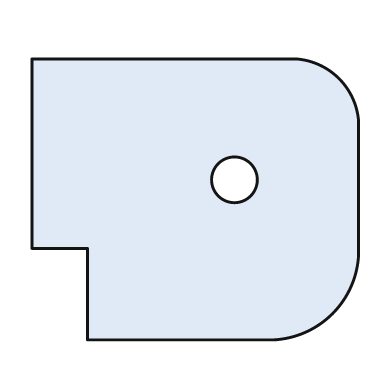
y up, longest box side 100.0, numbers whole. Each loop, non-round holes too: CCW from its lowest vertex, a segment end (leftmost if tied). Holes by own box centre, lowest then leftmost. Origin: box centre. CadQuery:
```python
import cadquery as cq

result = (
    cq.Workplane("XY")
    .moveTo(-33.0, -43.0)
    .lineTo(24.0, -43.0)
    .threePointArc((42.0, -35.0), (50.0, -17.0))
    .lineTo(50.0, 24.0)
    .threePointArc((44.0, 37.0), (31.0, 43.0))
    .lineTo(-50.0, 43.0)
    .lineTo(-50.0, -15.0)
    .lineTo(-33.0, -15.0)
    .close()
    .moveTo(12.0, 6.0)
    .circle(7.0)
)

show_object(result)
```